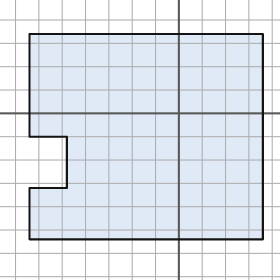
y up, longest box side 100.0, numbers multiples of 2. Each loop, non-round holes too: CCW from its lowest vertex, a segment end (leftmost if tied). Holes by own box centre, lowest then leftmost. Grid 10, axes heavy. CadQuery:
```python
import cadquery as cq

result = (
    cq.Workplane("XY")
    .moveTo(-64.0, -54.0)
    .lineTo(36.0, -54.0)
    .lineTo(36.0, 34.0)
    .lineTo(-64.0, 34.0)
    .lineTo(-64.0, -10.0)
    .lineTo(-48.0, -10.0)
    .lineTo(-48.0, -32.0)
    .lineTo(-64.0, -32.0)
    .close()
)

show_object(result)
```